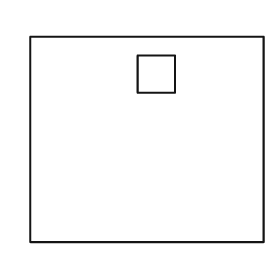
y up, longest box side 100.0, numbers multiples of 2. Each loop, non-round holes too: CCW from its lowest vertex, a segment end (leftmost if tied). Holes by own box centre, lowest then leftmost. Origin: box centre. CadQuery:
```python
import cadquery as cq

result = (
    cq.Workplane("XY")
    .moveTo(-50.0, -44.0)
    .lineTo(50.0, -44.0)
    .lineTo(50.0, 44.0)
    .lineTo(-50.0, 44.0)
    .close()
    .moveTo(-4.0, 20.0)
    .lineTo(12.0, 20.0)
    .lineTo(12.0, 36.0)
    .lineTo(-4.0, 36.0)
    .close()
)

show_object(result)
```